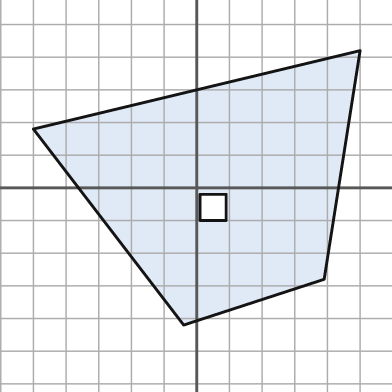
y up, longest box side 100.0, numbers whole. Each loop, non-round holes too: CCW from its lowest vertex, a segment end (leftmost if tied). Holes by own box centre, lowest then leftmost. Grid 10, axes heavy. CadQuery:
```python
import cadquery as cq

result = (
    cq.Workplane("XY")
    .moveTo(-4.0, -42.0)
    .lineTo(39.0, -28.0)
    .lineTo(50.0, 42.0)
    .lineTo(-50.0, 18.0)
    .close()
    .moveTo(1.0, -10.0)
    .lineTo(9.0, -10.0)
    .lineTo(9.0, -2.0)
    .lineTo(1.0, -2.0)
    .close()
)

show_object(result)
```